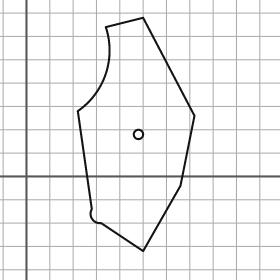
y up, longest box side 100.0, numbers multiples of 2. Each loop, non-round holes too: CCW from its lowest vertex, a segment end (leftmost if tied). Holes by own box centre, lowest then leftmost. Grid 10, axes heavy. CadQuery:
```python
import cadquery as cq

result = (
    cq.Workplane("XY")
    .moveTo(50.0, -32.0)
    .lineTo(66.0, -4.0)
    .lineTo(72.0, 26.0)
    .lineTo(50.0, 68.0)
    .lineTo(34.0, 64.0)
    .threePointArc((34.0, 44.0), (22.0, 28.0))
    .lineTo(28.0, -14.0)
    .threePointArc((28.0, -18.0), (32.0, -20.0))
    .close()
    .moveTo(48.0, 18.0)
    .circle(2.0)
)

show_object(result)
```